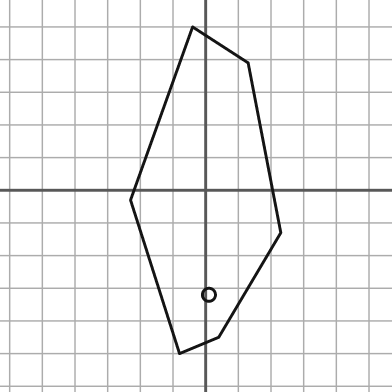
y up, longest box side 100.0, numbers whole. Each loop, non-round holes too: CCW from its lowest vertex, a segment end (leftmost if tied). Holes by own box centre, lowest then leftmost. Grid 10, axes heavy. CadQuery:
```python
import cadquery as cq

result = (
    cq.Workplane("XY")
    .moveTo(-8.0, -50.0)
    .lineTo(4.0, -45.0)
    .lineTo(23.0, -13.0)
    .lineTo(13.0, 39.0)
    .lineTo(-4.0, 50.0)
    .lineTo(-23.0, -3.0)
    .close()
    .moveTo(1.0, -32.0)
    .circle(2.0)
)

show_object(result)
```